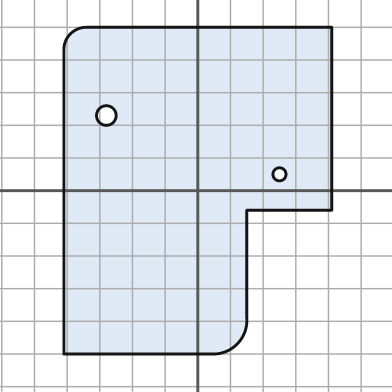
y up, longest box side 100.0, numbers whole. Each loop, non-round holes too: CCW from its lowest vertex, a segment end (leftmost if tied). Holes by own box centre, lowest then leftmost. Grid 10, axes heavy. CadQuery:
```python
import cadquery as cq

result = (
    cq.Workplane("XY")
    .moveTo(-41.0, -50.0)
    .lineTo(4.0, -50.0)
    .threePointArc((12.0, -47.0), (15.0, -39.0))
    .lineTo(15.0, -6.0)
    .lineTo(41.0, -6.0)
    .lineTo(41.0, 50.0)
    .lineTo(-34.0, 50.0)
    .threePointArc((-39.0, 48.0), (-41.0, 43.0))
    .close()
    .moveTo(25.0, 5.0)
    .circle(2.0)
    .moveTo(-28.0, 23.0)
    .circle(3.0)
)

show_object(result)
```